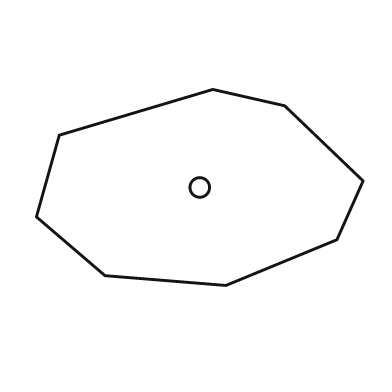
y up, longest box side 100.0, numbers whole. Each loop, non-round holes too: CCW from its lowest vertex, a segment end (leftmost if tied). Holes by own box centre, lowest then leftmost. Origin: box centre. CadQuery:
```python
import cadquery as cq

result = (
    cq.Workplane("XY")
    .moveTo(8.0, -30.0)
    .lineTo(42.0, -16.0)
    .lineTo(50.0, 2.0)
    .lineTo(26.0, 25.0)
    .lineTo(4.0, 30.0)
    .lineTo(-43.0, 16.0)
    .lineTo(-50.0, -9.0)
    .lineTo(-29.0, -27.0)
    .close()
    .moveTo(0.0, 0.0)
    .circle(3.0)
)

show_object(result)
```